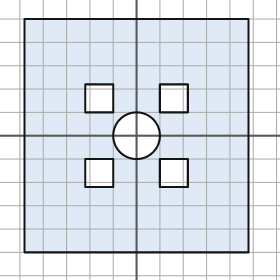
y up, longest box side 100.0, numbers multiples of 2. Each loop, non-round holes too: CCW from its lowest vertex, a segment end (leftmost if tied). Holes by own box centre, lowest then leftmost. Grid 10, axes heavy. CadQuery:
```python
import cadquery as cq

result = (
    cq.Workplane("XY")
    .moveTo(-48.0, -50.0)
    .lineTo(48.0, -50.0)
    .lineTo(48.0, 50.0)
    .lineTo(-48.0, 50.0)
    .close()
    .moveTo(-22.0, -22.0)
    .lineTo(-10.0, -22.0)
    .lineTo(-10.0, -10.0)
    .lineTo(-22.0, -10.0)
    .close()
    .moveTo(10.0, -22.0)
    .lineTo(22.0, -22.0)
    .lineTo(22.0, -10.0)
    .lineTo(10.0, -10.0)
    .close()
    .moveTo(0.0, 0.0)
    .circle(10.0)
    .moveTo(-22.0, 10.0)
    .lineTo(-10.0, 10.0)
    .lineTo(-10.0, 22.0)
    .lineTo(-22.0, 22.0)
    .close()
    .moveTo(10.0, 10.0)
    .lineTo(22.0, 10.0)
    .lineTo(22.0, 22.0)
    .lineTo(10.0, 22.0)
    .close()
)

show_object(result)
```